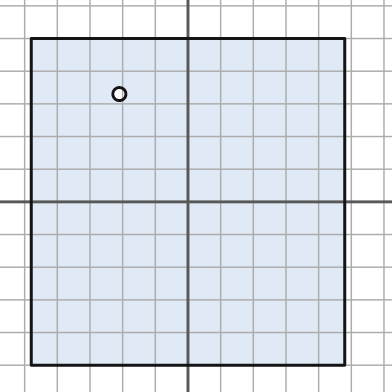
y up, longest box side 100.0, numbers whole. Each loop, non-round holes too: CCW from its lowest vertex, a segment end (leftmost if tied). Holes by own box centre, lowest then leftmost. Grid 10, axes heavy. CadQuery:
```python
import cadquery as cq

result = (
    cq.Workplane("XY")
    .moveTo(-48.0, -50.0)
    .lineTo(48.0, -50.0)
    .lineTo(48.0, 50.0)
    .lineTo(-48.0, 50.0)
    .close()
    .moveTo(-21.0, 33.0)
    .circle(2.0)
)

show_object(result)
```